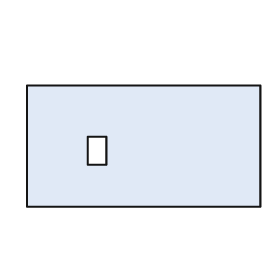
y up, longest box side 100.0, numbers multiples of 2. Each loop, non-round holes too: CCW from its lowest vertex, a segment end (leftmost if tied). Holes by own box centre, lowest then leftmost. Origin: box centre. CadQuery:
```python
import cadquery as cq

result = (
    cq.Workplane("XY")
    .moveTo(-50.0, -26.0)
    .lineTo(50.0, -26.0)
    .lineTo(50.0, 26.0)
    .lineTo(-50.0, 26.0)
    .close()
    .moveTo(-24.0, -8.0)
    .lineTo(-16.0, -8.0)
    .lineTo(-16.0, 4.0)
    .lineTo(-24.0, 4.0)
    .close()
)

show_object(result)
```